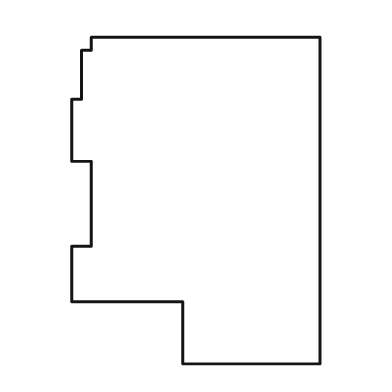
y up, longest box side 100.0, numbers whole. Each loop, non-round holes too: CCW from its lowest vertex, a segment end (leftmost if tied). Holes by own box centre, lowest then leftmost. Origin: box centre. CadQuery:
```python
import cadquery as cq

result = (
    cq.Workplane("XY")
    .moveTo(-4.0, -50.0)
    .lineTo(38.0, -50.0)
    .lineTo(38.0, 50.0)
    .lineTo(-32.0, 50.0)
    .lineTo(-32.0, 46.0)
    .lineTo(-35.0, 46.0)
    .lineTo(-35.0, 31.0)
    .lineTo(-38.0, 31.0)
    .lineTo(-38.0, 12.0)
    .lineTo(-32.0, 12.0)
    .lineTo(-32.0, -14.0)
    .lineTo(-38.0, -14.0)
    .lineTo(-38.0, -31.0)
    .lineTo(-4.0, -31.0)
    .close()
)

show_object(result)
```